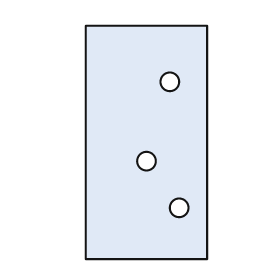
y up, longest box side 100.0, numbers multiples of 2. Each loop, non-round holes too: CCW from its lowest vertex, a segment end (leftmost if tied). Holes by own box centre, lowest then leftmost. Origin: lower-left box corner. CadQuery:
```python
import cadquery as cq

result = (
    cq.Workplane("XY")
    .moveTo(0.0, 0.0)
    .lineTo(52.0, 0.0)
    .lineTo(52.0, 100.0)
    .lineTo(0.0, 100.0)
    .close()
    .moveTo(40.0, 22.0)
    .circle(4.0)
    .moveTo(26.0, 42.0)
    .circle(4.0)
    .moveTo(36.0, 76.0)
    .circle(4.0)
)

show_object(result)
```